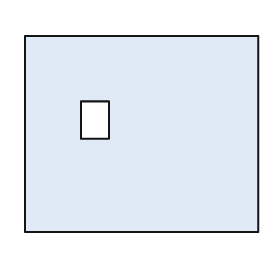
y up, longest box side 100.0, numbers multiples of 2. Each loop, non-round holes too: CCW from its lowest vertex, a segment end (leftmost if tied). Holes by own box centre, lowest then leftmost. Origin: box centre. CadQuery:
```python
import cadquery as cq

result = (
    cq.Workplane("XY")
    .moveTo(-50.0, -42.0)
    .lineTo(50.0, -42.0)
    .lineTo(50.0, 42.0)
    .lineTo(-50.0, 42.0)
    .close()
    .moveTo(-26.0, -2.0)
    .lineTo(-14.0, -2.0)
    .lineTo(-14.0, 14.0)
    .lineTo(-26.0, 14.0)
    .close()
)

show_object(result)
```